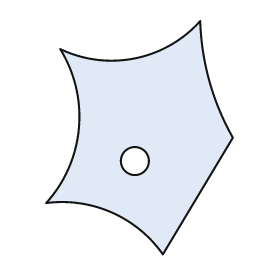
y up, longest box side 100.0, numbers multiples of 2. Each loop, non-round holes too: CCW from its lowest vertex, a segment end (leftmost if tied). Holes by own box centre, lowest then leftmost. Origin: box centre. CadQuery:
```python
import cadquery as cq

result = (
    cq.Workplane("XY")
    .moveTo(10.0, -50.0)
    .lineTo(40.0, 0.0)
    .threePointArc((30.0, 24.0), (26.0, 50.0))
    .threePointArc((-2.0, 34.0), (-34.0, 38.0))
    .threePointArc((-26.0, 4.0), (-40.0, -28.0))
    .threePointArc((-12.0, -32.0), (10.0, -50.0))
    .close()
    .moveTo(-2.0, -10.0)
    .circle(6.0)
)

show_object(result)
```